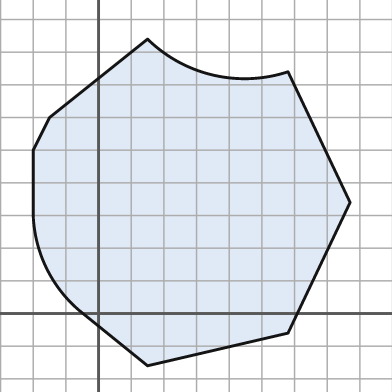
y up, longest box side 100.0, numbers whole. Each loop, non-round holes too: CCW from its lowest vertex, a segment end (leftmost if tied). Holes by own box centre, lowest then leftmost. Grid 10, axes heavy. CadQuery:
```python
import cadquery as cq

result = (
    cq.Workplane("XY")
    .moveTo(15.0, -16.0)
    .lineTo(58.0, -6.0)
    .lineTo(77.0, 34.0)
    .lineTo(58.0, 74.0)
    .threePointArc((35.0, 73.0), (15.0, 84.0))
    .lineTo(-15.0, 60.0)
    .lineTo(-20.0, 50.0)
    .lineTo(-20.0, 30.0)
    .threePointArc((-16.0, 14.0), (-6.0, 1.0))
    .close()
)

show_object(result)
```